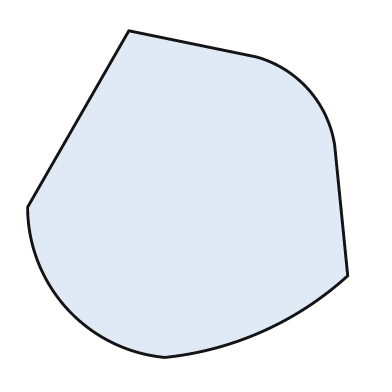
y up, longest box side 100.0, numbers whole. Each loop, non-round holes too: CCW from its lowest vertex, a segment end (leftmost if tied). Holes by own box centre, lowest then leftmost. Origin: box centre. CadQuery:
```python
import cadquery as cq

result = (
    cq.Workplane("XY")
    .moveTo(-7.0, -50.0)
    .threePointArc((23.0, -42.0), (49.0, -25.0))
    .lineTo(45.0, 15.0)
    .threePointArc((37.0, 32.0), (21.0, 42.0))
    .lineTo(-18.0, 50.0)
    .lineTo(-49.0, -4.0)
    .threePointArc((-37.0, -35.0), (-7.0, -50.0))
    .close()
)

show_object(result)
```